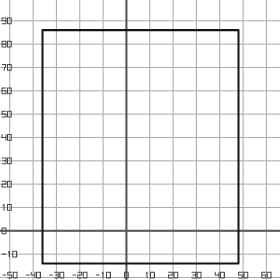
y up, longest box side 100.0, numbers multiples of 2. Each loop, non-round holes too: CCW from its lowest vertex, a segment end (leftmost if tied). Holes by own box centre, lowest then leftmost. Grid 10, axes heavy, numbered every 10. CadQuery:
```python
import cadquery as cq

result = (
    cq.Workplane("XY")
    .moveTo(-36.0, -14.0)
    .lineTo(48.0, -14.0)
    .lineTo(48.0, 86.0)
    .lineTo(-36.0, 86.0)
    .close()
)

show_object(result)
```